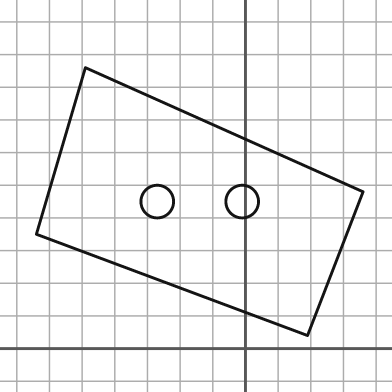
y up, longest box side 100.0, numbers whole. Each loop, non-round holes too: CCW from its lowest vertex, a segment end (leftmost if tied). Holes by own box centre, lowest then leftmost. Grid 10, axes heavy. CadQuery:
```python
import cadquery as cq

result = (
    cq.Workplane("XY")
    .moveTo(19.0, 4.0)
    .lineTo(36.0, 48.0)
    .lineTo(-49.0, 86.0)
    .lineTo(-64.0, 35.0)
    .close()
    .moveTo(-27.0, 45.0)
    .circle(5.0)
    .moveTo(-1.0, 45.0)
    .circle(5.0)
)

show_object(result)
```